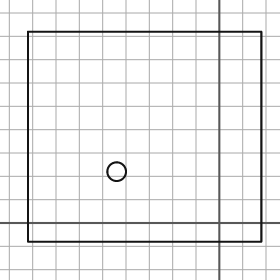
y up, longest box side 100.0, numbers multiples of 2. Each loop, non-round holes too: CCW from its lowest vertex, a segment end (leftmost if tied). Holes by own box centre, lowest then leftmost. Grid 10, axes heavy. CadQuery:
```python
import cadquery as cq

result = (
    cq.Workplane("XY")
    .moveTo(-82.0, -8.0)
    .lineTo(18.0, -8.0)
    .lineTo(18.0, 82.0)
    .lineTo(-82.0, 82.0)
    .close()
    .moveTo(-44.0, 22.0)
    .circle(4.0)
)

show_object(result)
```